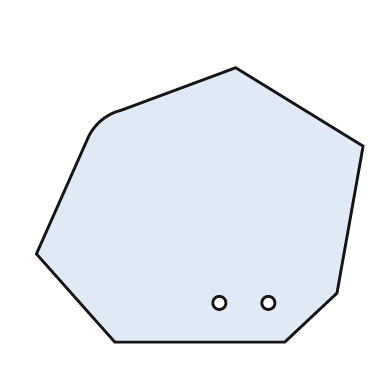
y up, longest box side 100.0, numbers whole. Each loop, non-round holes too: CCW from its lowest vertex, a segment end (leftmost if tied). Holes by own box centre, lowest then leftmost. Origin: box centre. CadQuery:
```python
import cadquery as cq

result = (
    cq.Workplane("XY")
    .moveTo(-26.0, -42.0)
    .lineTo(26.0, -42.0)
    .lineTo(42.0, -27.0)
    .lineTo(50.0, 18.0)
    .lineTo(11.0, 42.0)
    .lineTo(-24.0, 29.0)
    .threePointArc((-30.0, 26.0), (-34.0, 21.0))
    .lineTo(-50.0, -15.0)
    .close()
    .moveTo(6.0, -30.0)
    .circle(2.0)
    .moveTo(21.0, -30.0)
    .circle(2.0)
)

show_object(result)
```